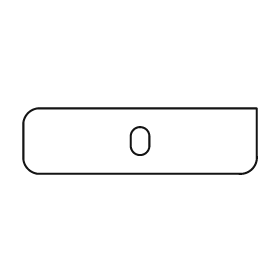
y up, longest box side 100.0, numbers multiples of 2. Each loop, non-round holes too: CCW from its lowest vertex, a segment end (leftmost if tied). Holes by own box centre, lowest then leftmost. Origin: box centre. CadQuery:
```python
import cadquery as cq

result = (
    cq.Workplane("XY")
    .moveTo(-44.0, -14.0)
    .lineTo(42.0, -14.0)
    .threePointArc((48.0, -12.0), (50.0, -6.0))
    .lineTo(50.0, 14.0)
    .lineTo(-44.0, 14.0)
    .threePointArc((-48.0, 12.0), (-50.0, 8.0))
    .lineTo(-50.0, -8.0)
    .threePointArc((-48.0, -12.0), (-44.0, -14.0))
    .close()
    .moveTo(-4.0, -2.0)
    .threePointArc((0.0, -6.0), (4.0, -2.0))
    .lineTo(4.0, 2.0)
    .threePointArc((0.0, 6.0), (-4.0, 2.0))
    .close()
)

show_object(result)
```